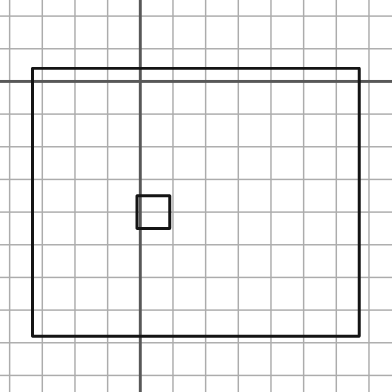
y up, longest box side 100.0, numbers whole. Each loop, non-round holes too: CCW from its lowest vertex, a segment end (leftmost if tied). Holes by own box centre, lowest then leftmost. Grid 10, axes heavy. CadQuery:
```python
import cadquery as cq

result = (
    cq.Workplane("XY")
    .moveTo(-33.0, -78.0)
    .lineTo(67.0, -78.0)
    .lineTo(67.0, 4.0)
    .lineTo(-33.0, 4.0)
    .close()
    .moveTo(-1.0, -45.0)
    .lineTo(9.0, -45.0)
    .lineTo(9.0, -35.0)
    .lineTo(-1.0, -35.0)
    .close()
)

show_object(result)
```